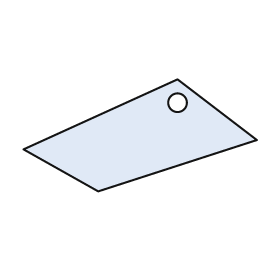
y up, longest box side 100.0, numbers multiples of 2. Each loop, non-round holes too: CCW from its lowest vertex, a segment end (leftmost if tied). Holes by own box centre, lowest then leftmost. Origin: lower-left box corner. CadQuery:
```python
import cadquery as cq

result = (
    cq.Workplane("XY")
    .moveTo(32.0, 0.0)
    .lineTo(100.0, 22.0)
    .lineTo(66.0, 48.0)
    .lineTo(0.0, 18.0)
    .close()
    .moveTo(66.0, 38.0)
    .circle(4.0)
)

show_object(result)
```